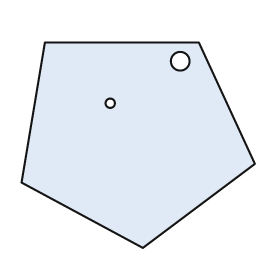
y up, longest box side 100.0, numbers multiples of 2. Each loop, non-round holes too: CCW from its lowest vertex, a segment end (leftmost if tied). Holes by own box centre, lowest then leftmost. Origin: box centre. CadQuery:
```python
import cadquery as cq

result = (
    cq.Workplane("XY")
    .moveTo(2.0, -44.0)
    .lineTo(50.0, -8.0)
    .lineTo(26.0, 44.0)
    .lineTo(-40.0, 44.0)
    .lineTo(-50.0, -16.0)
    .close()
    .moveTo(-12.0, 18.0)
    .circle(2.0)
    .moveTo(18.0, 36.0)
    .circle(4.0)
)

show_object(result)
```